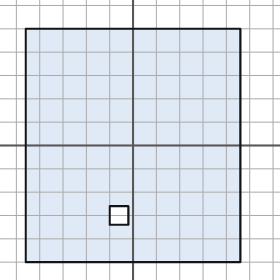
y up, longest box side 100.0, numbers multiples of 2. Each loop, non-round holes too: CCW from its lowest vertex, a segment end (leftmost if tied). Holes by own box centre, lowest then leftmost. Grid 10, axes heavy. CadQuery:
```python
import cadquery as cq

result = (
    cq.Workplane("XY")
    .moveTo(-46.0, -50.0)
    .lineTo(46.0, -50.0)
    .lineTo(46.0, 50.0)
    .lineTo(-46.0, 50.0)
    .close()
    .moveTo(-10.0, -34.0)
    .lineTo(-2.0, -34.0)
    .lineTo(-2.0, -26.0)
    .lineTo(-10.0, -26.0)
    .close()
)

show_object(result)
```